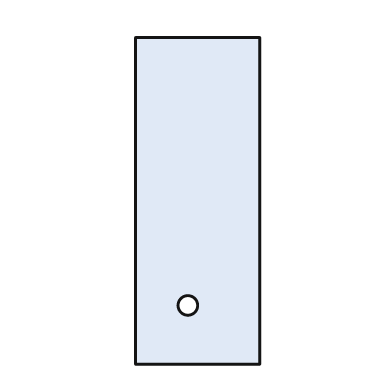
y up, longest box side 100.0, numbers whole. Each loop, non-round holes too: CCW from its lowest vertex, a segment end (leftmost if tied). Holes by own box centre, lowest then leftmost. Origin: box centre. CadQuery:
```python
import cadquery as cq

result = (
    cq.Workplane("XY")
    .moveTo(-19.0, -50.0)
    .lineTo(19.0, -50.0)
    .lineTo(19.0, 50.0)
    .lineTo(-19.0, 50.0)
    .close()
    .moveTo(-3.0, -32.0)
    .circle(3.0)
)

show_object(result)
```